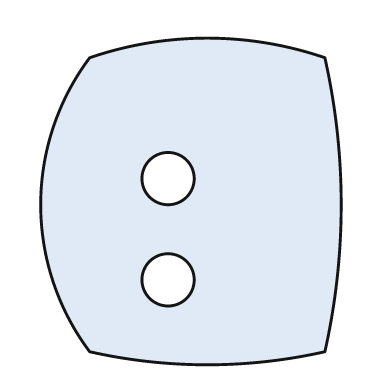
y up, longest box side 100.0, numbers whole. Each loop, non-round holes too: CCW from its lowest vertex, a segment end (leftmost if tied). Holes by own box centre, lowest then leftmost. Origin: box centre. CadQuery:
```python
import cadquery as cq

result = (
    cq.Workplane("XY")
    .moveTo(-31.0, -46.0)
    .threePointArc((5.0, -50.0), (41.0, -46.0))
    .threePointArc((46.0, -1.0), (41.0, 44.0))
    .threePointArc((5.0, 50.0), (-31.0, 44.0))
    .threePointArc((-46.0, -1.0), (-31.0, -46.0))
    .close()
    .moveTo(-7.0, -24.0)
    .circle(8.0)
    .moveTo(-7.0, 7.0)
    .circle(8.0)
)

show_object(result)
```